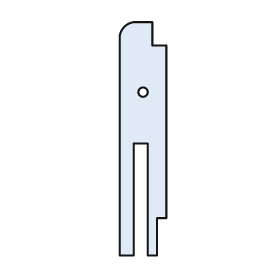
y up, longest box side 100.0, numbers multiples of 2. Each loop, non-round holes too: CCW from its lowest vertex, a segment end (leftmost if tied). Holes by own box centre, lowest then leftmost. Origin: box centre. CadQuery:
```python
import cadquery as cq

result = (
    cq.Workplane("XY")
    .moveTo(-10.0, -50.0)
    .lineTo(-4.0, -50.0)
    .lineTo(-4.0, -2.0)
    .lineTo(2.0, -2.0)
    .lineTo(2.0, -50.0)
    .lineTo(6.0, -50.0)
    .lineTo(6.0, -34.0)
    .lineTo(10.0, -34.0)
    .lineTo(10.0, 40.0)
    .lineTo(4.0, 40.0)
    .lineTo(4.0, 50.0)
    .lineTo(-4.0, 50.0)
    .threePointArc((-8.0, 48.0), (-10.0, 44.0))
    .close()
    .moveTo(0.0, 20.0)
    .circle(2.0)
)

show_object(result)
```